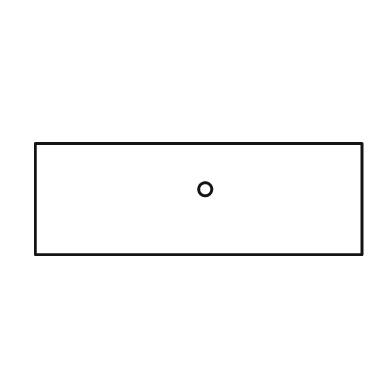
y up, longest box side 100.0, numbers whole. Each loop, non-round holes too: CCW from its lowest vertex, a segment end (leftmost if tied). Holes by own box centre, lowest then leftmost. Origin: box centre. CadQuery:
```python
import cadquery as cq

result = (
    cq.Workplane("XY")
    .moveTo(-50.0, -17.0)
    .lineTo(50.0, -17.0)
    .lineTo(50.0, 17.0)
    .lineTo(-50.0, 17.0)
    .close()
    .moveTo(2.0, 3.0)
    .circle(2.0)
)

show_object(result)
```